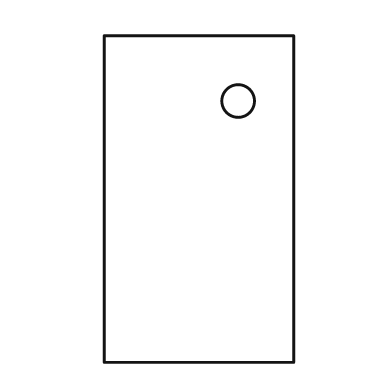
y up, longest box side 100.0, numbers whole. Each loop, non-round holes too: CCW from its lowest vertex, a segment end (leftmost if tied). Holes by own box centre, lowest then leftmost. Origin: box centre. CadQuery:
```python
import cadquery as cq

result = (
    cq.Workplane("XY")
    .moveTo(-29.0, -50.0)
    .lineTo(29.0, -50.0)
    .lineTo(29.0, 50.0)
    .lineTo(-29.0, 50.0)
    .close()
    .moveTo(12.0, 30.0)
    .circle(5.0)
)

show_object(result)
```